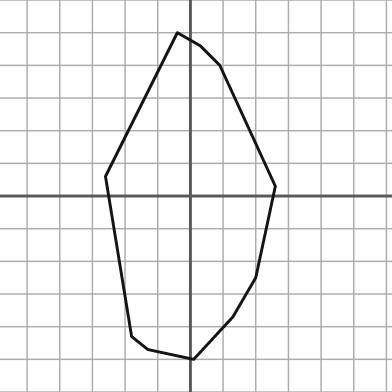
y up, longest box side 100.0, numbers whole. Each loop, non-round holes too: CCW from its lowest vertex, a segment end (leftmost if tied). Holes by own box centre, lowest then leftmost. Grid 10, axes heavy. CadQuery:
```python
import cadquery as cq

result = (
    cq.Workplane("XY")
    .moveTo(1.0, -50.0)
    .lineTo(13.0, -37.0)
    .lineTo(20.0, -25.0)
    .lineTo(26.0, 3.0)
    .lineTo(9.0, 40.0)
    .lineTo(3.0, 46.0)
    .lineTo(-4.0, 50.0)
    .lineTo(-26.0, 6.0)
    .lineTo(-18.0, -43.0)
    .lineTo(-13.0, -47.0)
    .close()
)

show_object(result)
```